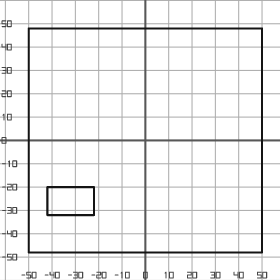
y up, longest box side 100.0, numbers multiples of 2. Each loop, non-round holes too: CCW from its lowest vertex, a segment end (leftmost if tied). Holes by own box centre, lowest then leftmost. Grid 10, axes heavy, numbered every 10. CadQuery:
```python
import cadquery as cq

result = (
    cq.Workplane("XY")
    .moveTo(-50.0, -48.0)
    .lineTo(50.0, -48.0)
    .lineTo(50.0, 48.0)
    .lineTo(-50.0, 48.0)
    .close()
    .moveTo(-42.0, -32.0)
    .lineTo(-22.0, -32.0)
    .lineTo(-22.0, -20.0)
    .lineTo(-42.0, -20.0)
    .close()
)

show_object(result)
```